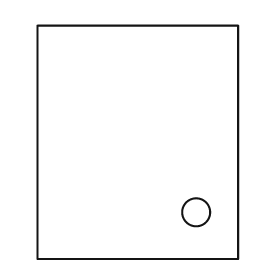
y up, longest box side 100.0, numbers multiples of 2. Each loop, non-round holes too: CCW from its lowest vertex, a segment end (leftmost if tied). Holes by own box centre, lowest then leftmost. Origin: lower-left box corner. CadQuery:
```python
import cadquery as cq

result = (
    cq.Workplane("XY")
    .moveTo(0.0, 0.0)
    .lineTo(86.0, 0.0)
    .lineTo(86.0, 100.0)
    .lineTo(0.0, 100.0)
    .close()
    .moveTo(68.0, 20.0)
    .circle(6.0)
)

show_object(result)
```